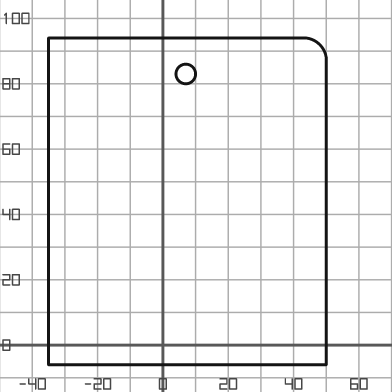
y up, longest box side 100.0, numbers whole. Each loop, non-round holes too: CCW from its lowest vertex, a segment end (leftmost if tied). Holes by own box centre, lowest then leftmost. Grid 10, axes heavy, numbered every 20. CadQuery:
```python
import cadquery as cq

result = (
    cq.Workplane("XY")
    .moveTo(-35.0, -6.0)
    .lineTo(50.0, -6.0)
    .lineTo(50.0, 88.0)
    .threePointArc((48.0, 92.0), (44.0, 94.0))
    .lineTo(-35.0, 94.0)
    .close()
    .moveTo(7.0, 83.0)
    .circle(3.0)
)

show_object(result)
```